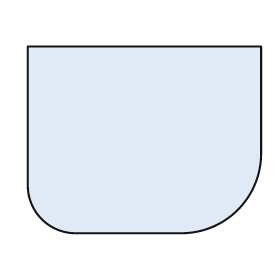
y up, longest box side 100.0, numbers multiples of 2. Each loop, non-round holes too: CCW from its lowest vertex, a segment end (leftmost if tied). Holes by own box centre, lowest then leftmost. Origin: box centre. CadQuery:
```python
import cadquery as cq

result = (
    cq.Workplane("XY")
    .moveTo(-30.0, -40.0)
    .lineTo(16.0, -40.0)
    .threePointArc((40.0, -30.0), (50.0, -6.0))
    .lineTo(50.0, 40.0)
    .lineTo(-50.0, 40.0)
    .lineTo(-50.0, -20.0)
    .threePointArc((-44.0, -34.0), (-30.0, -40.0))
    .close()
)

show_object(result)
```